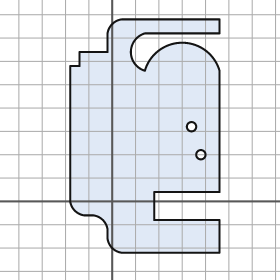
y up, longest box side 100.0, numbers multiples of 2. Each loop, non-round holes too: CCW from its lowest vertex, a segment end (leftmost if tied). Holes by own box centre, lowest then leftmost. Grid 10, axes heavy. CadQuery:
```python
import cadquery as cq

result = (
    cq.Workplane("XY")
    .moveTo(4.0, -22.0)
    .lineTo(46.0, -22.0)
    .lineTo(46.0, -8.0)
    .lineTo(18.0, -8.0)
    .lineTo(18.0, 4.0)
    .lineTo(46.0, 4.0)
    .lineTo(46.0, 56.0)
    .threePointArc((30.0, 68.0), (14.0, 56.0))
    .threePointArc((8.0, 64.0), (14.0, 72.0))
    .lineTo(46.0, 72.0)
    .lineTo(46.0, 78.0)
    .lineTo(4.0, 78.0)
    .threePointArc((0.0, 76.0), (-2.0, 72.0))
    .lineTo(-2.0, 64.0)
    .lineTo(-14.0, 64.0)
    .lineTo(-14.0, 58.0)
    .lineTo(-18.0, 58.0)
    .lineTo(-18.0, 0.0)
    .threePointArc((-16.0, -4.0), (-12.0, -6.0))
    .lineTo(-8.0, -6.0)
    .threePointArc((-4.0, -8.0), (-2.0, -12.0))
    .lineTo(-2.0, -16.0)
    .threePointArc((0.0, -20.0), (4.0, -22.0))
    .close()
    .moveTo(38.0, 20.0)
    .circle(2.0)
    .moveTo(34.0, 32.0)
    .circle(2.0)
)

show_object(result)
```